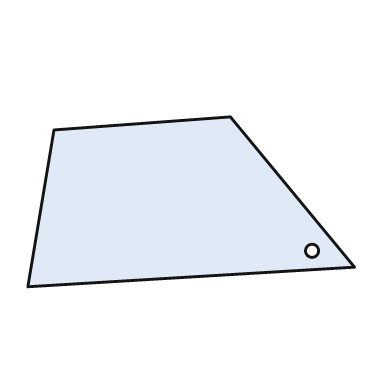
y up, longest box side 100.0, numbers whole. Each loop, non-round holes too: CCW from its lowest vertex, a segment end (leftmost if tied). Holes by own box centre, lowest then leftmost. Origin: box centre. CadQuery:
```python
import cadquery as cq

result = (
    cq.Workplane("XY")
    .moveTo(-50.0, -26.0)
    .lineTo(50.0, -20.0)
    .lineTo(12.0, 26.0)
    .lineTo(-42.0, 22.0)
    .close()
    .moveTo(37.0, -15.0)
    .circle(2.0)
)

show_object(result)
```